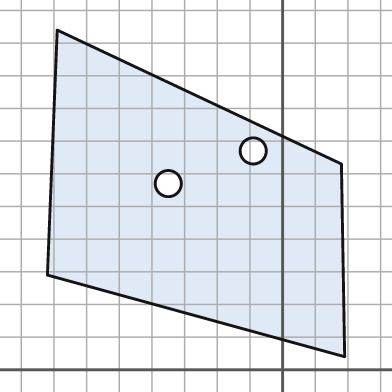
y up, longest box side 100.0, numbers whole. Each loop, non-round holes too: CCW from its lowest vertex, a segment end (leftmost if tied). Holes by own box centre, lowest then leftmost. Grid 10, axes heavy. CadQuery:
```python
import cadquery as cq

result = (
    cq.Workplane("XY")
    .moveTo(19.0, 4.0)
    .lineTo(18.0, 63.0)
    .lineTo(-69.0, 104.0)
    .lineTo(-72.0, 29.0)
    .close()
    .moveTo(-35.0, 57.0)
    .circle(4.0)
    .moveTo(-9.0, 67.0)
    .circle(4.0)
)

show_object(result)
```